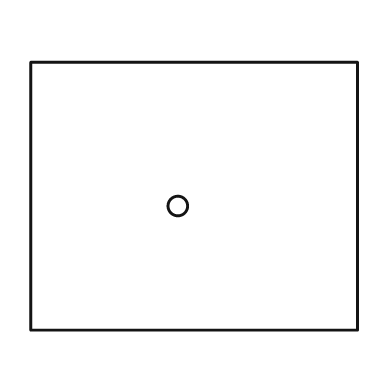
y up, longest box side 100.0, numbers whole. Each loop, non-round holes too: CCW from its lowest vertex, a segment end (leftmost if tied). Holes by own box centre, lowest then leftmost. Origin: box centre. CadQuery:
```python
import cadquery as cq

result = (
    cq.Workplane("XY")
    .moveTo(-50.0, -41.0)
    .lineTo(50.0, -41.0)
    .lineTo(50.0, 41.0)
    .lineTo(-50.0, 41.0)
    .close()
    .moveTo(-5.0, -3.0)
    .circle(3.0)
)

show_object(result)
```